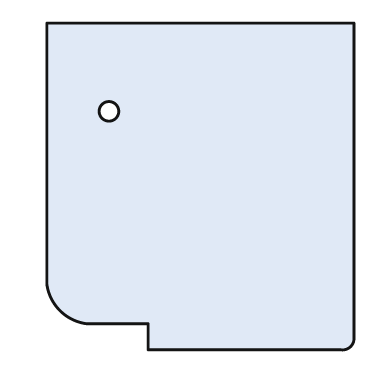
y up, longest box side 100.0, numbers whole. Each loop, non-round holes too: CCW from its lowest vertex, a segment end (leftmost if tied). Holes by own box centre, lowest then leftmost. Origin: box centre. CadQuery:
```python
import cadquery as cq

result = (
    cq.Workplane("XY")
    .moveTo(-16.0, -50.0)
    .lineTo(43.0, -50.0)
    .threePointArc((46.0, -49.0), (47.0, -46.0))
    .lineTo(47.0, 50.0)
    .lineTo(-47.0, 50.0)
    .lineTo(-47.0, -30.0)
    .threePointArc((-43.0, -38.0), (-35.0, -42.0))
    .lineTo(-16.0, -42.0)
    .close()
    .moveTo(-28.0, 23.0)
    .circle(3.0)
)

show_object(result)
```